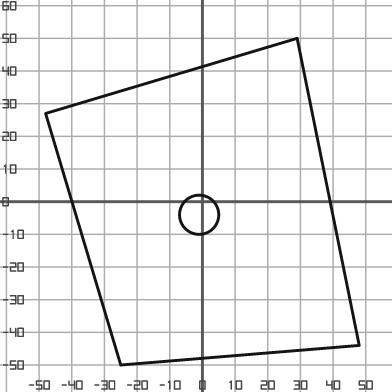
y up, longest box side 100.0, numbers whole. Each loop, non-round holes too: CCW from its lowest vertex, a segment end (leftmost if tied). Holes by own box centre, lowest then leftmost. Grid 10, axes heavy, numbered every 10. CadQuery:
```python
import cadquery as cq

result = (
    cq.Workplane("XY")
    .moveTo(-25.0, -50.0)
    .lineTo(48.0, -44.0)
    .lineTo(29.0, 50.0)
    .lineTo(-48.0, 27.0)
    .close()
    .moveTo(-1.0, -4.0)
    .circle(6.0)
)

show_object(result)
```